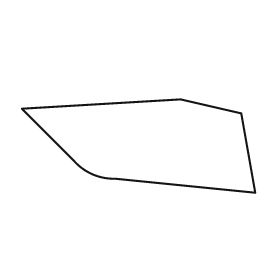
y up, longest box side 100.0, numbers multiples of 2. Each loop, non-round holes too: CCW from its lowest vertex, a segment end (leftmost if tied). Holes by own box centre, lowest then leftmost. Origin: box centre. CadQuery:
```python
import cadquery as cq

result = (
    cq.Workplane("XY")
    .moveTo(50.0, -20.0)
    .lineTo(44.0, 14.0)
    .lineTo(18.0, 20.0)
    .lineTo(-50.0, 16.0)
    .lineTo(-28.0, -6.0)
    .threePointArc((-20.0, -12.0), (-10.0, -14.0))
    .close()
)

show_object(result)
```